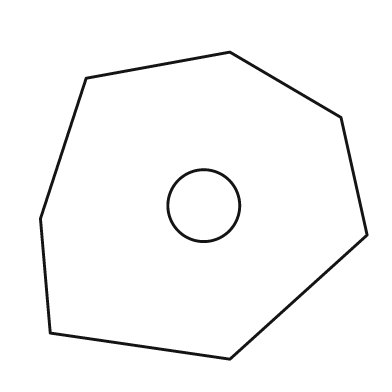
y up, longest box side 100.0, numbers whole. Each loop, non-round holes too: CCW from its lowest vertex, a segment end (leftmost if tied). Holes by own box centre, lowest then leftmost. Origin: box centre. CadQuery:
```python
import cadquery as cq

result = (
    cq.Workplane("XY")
    .moveTo(8.0, -47.0)
    .lineTo(50.0, -9.0)
    .lineTo(42.0, 27.0)
    .lineTo(8.0, 47.0)
    .lineTo(-36.0, 39.0)
    .lineTo(-50.0, -4.0)
    .lineTo(-47.0, -39.0)
    .close()
    .moveTo(0.0, 0.0)
    .circle(11.0)
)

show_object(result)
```